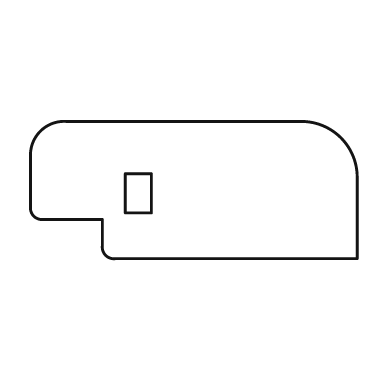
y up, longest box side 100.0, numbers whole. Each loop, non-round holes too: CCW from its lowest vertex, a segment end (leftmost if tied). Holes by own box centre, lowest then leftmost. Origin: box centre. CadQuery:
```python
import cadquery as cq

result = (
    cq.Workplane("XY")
    .moveTo(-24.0, -21.0)
    .lineTo(50.0, -21.0)
    .lineTo(50.0, 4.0)
    .threePointArc((45.0, 16.0), (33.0, 21.0))
    .lineTo(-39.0, 21.0)
    .threePointArc((-47.0, 18.0), (-50.0, 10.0))
    .lineTo(-50.0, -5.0)
    .threePointArc((-49.0, -8.0), (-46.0, -9.0))
    .lineTo(-28.0, -9.0)
    .lineTo(-28.0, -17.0)
    .threePointArc((-27.0, -20.0), (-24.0, -21.0))
    .close()
    .moveTo(-21.0, -7.0)
    .lineTo(-13.0, -7.0)
    .lineTo(-13.0, 5.0)
    .lineTo(-21.0, 5.0)
    .close()
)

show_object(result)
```